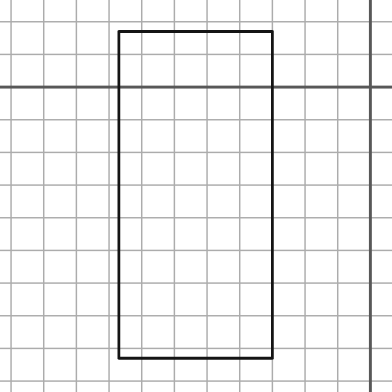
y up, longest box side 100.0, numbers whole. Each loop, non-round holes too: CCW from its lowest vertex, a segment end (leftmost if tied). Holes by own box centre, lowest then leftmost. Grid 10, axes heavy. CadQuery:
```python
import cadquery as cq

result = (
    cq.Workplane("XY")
    .moveTo(-77.0, -83.0)
    .lineTo(-30.0, -83.0)
    .lineTo(-30.0, 17.0)
    .lineTo(-77.0, 17.0)
    .close()
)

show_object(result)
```